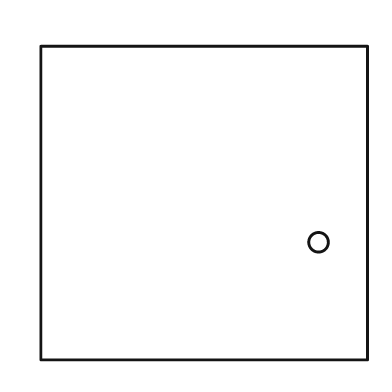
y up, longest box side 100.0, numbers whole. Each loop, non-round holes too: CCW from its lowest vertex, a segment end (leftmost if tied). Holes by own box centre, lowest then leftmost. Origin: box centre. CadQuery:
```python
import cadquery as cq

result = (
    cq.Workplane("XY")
    .moveTo(-50.0, -48.0)
    .lineTo(50.0, -48.0)
    .lineTo(50.0, 48.0)
    .lineTo(-50.0, 48.0)
    .close()
    .moveTo(35.0, -12.0)
    .circle(3.0)
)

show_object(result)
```